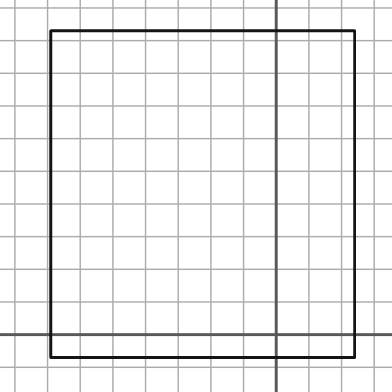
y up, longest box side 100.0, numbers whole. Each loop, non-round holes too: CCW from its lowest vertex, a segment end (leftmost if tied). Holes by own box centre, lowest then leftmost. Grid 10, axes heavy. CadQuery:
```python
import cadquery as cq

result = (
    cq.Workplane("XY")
    .moveTo(-69.0, -7.0)
    .lineTo(24.0, -7.0)
    .lineTo(24.0, 93.0)
    .lineTo(-69.0, 93.0)
    .close()
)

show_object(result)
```